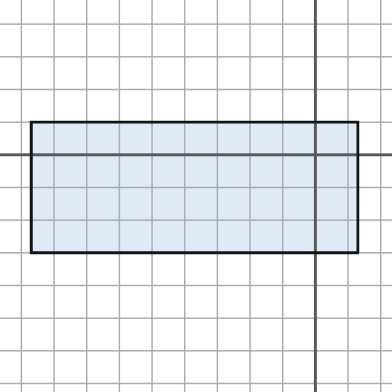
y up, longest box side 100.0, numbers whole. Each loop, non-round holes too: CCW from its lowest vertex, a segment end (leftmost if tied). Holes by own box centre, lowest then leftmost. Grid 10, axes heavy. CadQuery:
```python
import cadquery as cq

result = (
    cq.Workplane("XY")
    .moveTo(-87.0, -30.0)
    .lineTo(13.0, -30.0)
    .lineTo(13.0, 10.0)
    .lineTo(-87.0, 10.0)
    .close()
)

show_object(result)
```